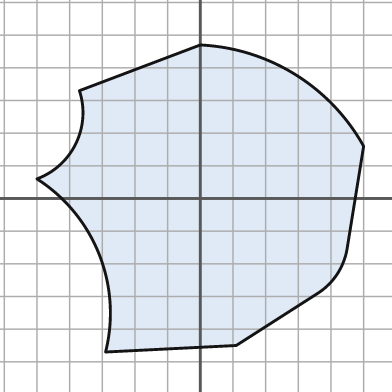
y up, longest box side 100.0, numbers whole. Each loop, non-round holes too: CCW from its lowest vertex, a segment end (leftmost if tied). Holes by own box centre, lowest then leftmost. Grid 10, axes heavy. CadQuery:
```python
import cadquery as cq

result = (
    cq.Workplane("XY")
    .moveTo(-29.0, -47.0)
    .lineTo(11.0, -45.0)
    .lineTo(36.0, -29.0)
    .threePointArc((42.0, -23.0), (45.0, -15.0))
    .lineTo(50.0, 16.0)
    .threePointArc((29.0, 38.0), (0.0, 47.0))
    .lineTo(-37.0, 33.0)
    .threePointArc((-38.0, 17.0), (-50.0, 6.0))
    .threePointArc((-31.0, -17.0), (-29.0, -47.0))
    .close()
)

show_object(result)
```